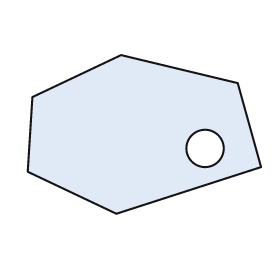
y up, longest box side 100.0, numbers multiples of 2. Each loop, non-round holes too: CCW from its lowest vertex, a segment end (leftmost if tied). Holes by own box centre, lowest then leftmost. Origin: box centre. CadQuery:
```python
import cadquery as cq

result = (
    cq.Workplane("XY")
    .moveTo(-12.0, -34.0)
    .lineTo(50.0, -14.0)
    .lineTo(40.0, 22.0)
    .lineTo(-10.0, 34.0)
    .lineTo(-48.0, 16.0)
    .lineTo(-50.0, -16.0)
    .close()
    .moveTo(26.0, -6.0)
    .circle(8.0)
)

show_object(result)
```